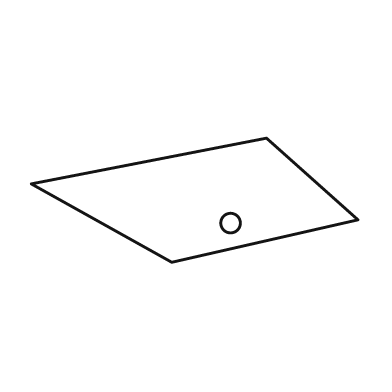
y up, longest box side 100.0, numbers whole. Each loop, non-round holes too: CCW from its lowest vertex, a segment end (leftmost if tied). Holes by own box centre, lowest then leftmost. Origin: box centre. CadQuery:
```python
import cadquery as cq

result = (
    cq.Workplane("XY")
    .moveTo(-7.0, -19.0)
    .lineTo(50.0, -6.0)
    .lineTo(22.0, 19.0)
    .lineTo(-50.0, 5.0)
    .close()
    .moveTo(11.0, -7.0)
    .circle(3.0)
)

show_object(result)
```